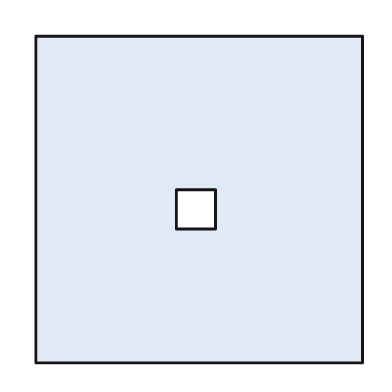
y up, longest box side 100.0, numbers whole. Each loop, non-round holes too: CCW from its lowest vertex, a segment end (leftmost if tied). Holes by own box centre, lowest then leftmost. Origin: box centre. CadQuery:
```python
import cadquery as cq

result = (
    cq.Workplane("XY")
    .moveTo(-50.0, -50.0)
    .lineTo(50.0, -50.0)
    .lineTo(50.0, 50.0)
    .lineTo(-50.0, 50.0)
    .close()
    .moveTo(-7.0, -9.0)
    .lineTo(5.0, -9.0)
    .lineTo(5.0, 3.0)
    .lineTo(-7.0, 3.0)
    .close()
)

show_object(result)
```